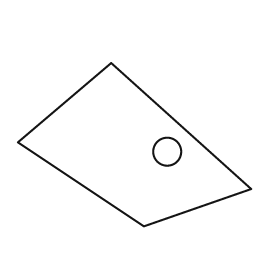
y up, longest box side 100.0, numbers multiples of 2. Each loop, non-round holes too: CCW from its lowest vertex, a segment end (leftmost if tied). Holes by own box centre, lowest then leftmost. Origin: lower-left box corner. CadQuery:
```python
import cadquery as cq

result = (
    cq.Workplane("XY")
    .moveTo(54.0, 0.0)
    .lineTo(100.0, 16.0)
    .lineTo(40.0, 70.0)
    .lineTo(0.0, 36.0)
    .close()
    .moveTo(64.0, 32.0)
    .circle(6.0)
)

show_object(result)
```